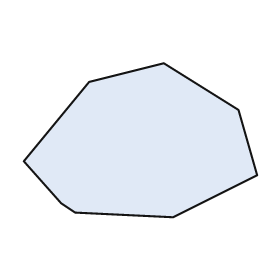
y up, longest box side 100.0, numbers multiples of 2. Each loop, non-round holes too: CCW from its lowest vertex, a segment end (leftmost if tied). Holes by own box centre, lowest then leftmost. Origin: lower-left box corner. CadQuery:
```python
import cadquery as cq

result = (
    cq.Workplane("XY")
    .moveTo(64.0, 0.0)
    .lineTo(100.0, 18.0)
    .lineTo(92.0, 46.0)
    .lineTo(60.0, 66.0)
    .lineTo(28.0, 58.0)
    .lineTo(0.0, 24.0)
    .lineTo(16.0, 6.0)
    .lineTo(22.0, 2.0)
    .close()
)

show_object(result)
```